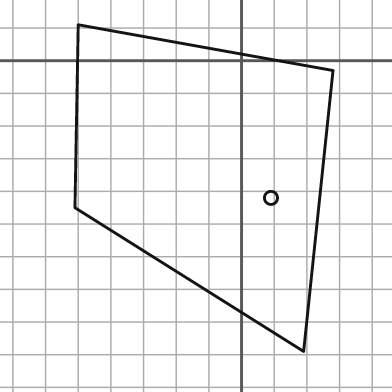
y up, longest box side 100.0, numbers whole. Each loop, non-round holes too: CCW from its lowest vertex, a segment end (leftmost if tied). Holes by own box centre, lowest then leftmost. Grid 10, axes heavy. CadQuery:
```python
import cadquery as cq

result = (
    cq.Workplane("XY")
    .moveTo(19.0, -89.0)
    .lineTo(28.0, -3.0)
    .lineTo(-50.0, 11.0)
    .lineTo(-51.0, -45.0)
    .close()
    .moveTo(9.0, -42.0)
    .circle(2.0)
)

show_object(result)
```